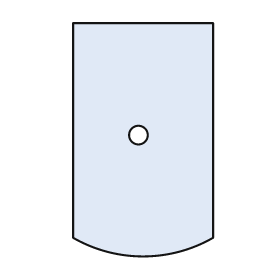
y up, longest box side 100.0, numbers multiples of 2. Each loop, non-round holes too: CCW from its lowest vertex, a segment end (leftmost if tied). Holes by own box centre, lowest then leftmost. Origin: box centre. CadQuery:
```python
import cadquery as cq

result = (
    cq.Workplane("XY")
    .moveTo(-30.0, -42.0)
    .threePointArc((0.0, -50.0), (30.0, -42.0))
    .lineTo(30.0, 50.0)
    .lineTo(-30.0, 50.0)
    .close()
    .moveTo(-2.0, 2.0)
    .circle(4.0)
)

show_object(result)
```